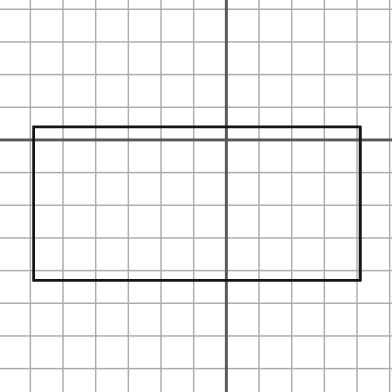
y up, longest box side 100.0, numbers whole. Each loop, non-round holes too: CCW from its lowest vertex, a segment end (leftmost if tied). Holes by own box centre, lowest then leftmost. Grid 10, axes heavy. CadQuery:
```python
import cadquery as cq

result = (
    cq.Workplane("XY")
    .moveTo(-59.0, -43.0)
    .lineTo(41.0, -43.0)
    .lineTo(41.0, 4.0)
    .lineTo(-59.0, 4.0)
    .close()
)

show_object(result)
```